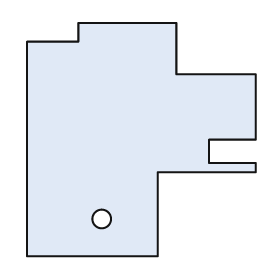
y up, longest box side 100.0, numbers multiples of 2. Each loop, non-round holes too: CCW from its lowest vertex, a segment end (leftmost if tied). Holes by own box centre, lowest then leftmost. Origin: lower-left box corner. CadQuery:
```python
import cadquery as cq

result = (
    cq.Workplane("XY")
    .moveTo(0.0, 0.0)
    .lineTo(56.0, 0.0)
    .lineTo(56.0, 36.0)
    .lineTo(98.0, 36.0)
    .lineTo(98.0, 40.0)
    .lineTo(78.0, 40.0)
    .lineTo(78.0, 50.0)
    .lineTo(98.0, 50.0)
    .lineTo(98.0, 78.0)
    .lineTo(64.0, 78.0)
    .lineTo(64.0, 100.0)
    .lineTo(22.0, 100.0)
    .lineTo(22.0, 92.0)
    .lineTo(0.0, 92.0)
    .close()
    .moveTo(32.0, 16.0)
    .circle(4.0)
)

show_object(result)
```